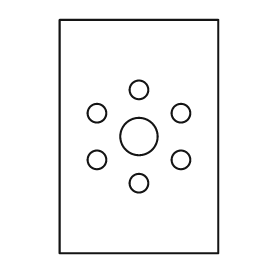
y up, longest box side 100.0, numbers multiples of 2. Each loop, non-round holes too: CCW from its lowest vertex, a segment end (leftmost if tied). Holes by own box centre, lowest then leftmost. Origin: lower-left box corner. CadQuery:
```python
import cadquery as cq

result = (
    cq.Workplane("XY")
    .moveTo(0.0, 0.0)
    .lineTo(68.0, 0.0)
    .lineTo(68.0, 100.0)
    .lineTo(0.0, 100.0)
    .close()
    .moveTo(34.0, 30.0)
    .circle(4.0)
    .moveTo(16.0, 40.0)
    .circle(4.0)
    .moveTo(52.0, 40.0)
    .circle(4.0)
    .moveTo(34.0, 50.0)
    .circle(8.0)
    .moveTo(16.0, 60.0)
    .circle(4.0)
    .moveTo(52.0, 60.0)
    .circle(4.0)
    .moveTo(34.0, 70.0)
    .circle(4.0)
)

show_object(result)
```